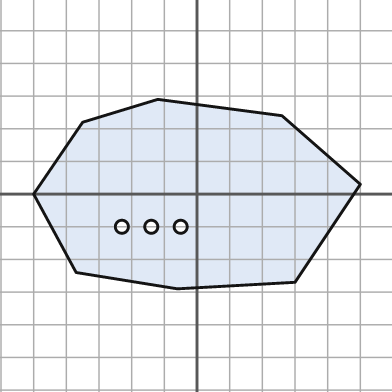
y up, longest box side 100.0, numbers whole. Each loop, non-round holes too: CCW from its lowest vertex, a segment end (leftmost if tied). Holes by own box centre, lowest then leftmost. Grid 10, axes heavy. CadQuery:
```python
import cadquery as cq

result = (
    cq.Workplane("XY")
    .moveTo(-6.0, -29.0)
    .lineTo(30.0, -27.0)
    .lineTo(50.0, 3.0)
    .lineTo(26.0, 24.0)
    .lineTo(-12.0, 29.0)
    .lineTo(-35.0, 22.0)
    .lineTo(-50.0, 0.0)
    .lineTo(-37.0, -24.0)
    .close()
    .moveTo(-23.0, -10.0)
    .circle(2.0)
    .moveTo(-14.0, -10.0)
    .circle(2.0)
    .moveTo(-5.0, -10.0)
    .circle(2.0)
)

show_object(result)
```